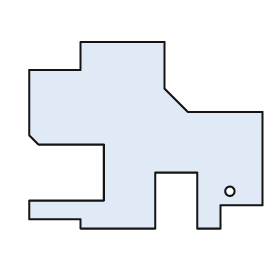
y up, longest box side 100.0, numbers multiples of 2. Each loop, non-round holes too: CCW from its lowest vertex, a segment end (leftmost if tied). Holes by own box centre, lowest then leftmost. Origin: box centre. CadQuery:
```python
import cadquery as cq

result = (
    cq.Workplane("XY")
    .moveTo(-28.0, -40.0)
    .lineTo(4.0, -40.0)
    .lineTo(4.0, -16.0)
    .lineTo(22.0, -16.0)
    .lineTo(22.0, -40.0)
    .lineTo(32.0, -40.0)
    .lineTo(32.0, -30.0)
    .lineTo(50.0, -30.0)
    .lineTo(50.0, 10.0)
    .lineTo(18.0, 10.0)
    .lineTo(8.0, 20.0)
    .lineTo(8.0, 40.0)
    .lineTo(-28.0, 40.0)
    .lineTo(-28.0, 28.0)
    .lineTo(-50.0, 28.0)
    .lineTo(-50.0, 0.0)
    .lineTo(-46.0, -4.0)
    .lineTo(-18.0, -4.0)
    .lineTo(-18.0, -28.0)
    .lineTo(-50.0, -28.0)
    .lineTo(-50.0, -36.0)
    .lineTo(-28.0, -36.0)
    .close()
    .moveTo(36.0, -24.0)
    .circle(2.0)
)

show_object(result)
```